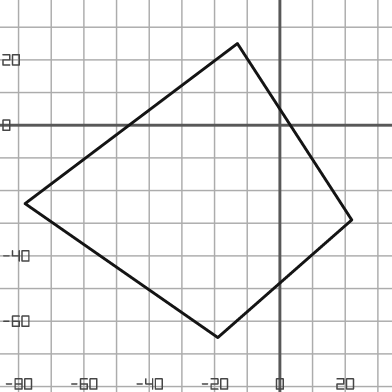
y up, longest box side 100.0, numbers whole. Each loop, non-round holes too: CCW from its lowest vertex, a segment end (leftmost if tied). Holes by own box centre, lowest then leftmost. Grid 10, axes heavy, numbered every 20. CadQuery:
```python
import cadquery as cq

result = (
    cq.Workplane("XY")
    .moveTo(-19.0, -65.0)
    .lineTo(22.0, -29.0)
    .lineTo(-13.0, 25.0)
    .lineTo(-78.0, -24.0)
    .close()
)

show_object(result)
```